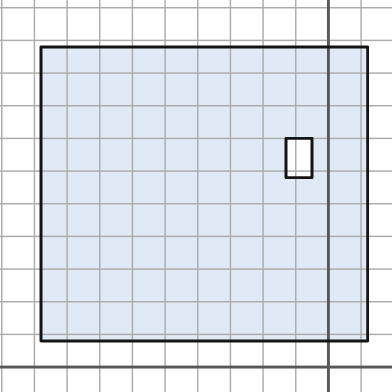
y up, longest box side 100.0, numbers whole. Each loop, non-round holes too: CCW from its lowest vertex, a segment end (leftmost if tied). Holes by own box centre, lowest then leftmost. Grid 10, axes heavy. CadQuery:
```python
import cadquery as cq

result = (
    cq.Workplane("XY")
    .moveTo(-88.0, 8.0)
    .lineTo(12.0, 8.0)
    .lineTo(12.0, 98.0)
    .lineTo(-88.0, 98.0)
    .close()
    .moveTo(-13.0, 58.0)
    .lineTo(-5.0, 58.0)
    .lineTo(-5.0, 70.0)
    .lineTo(-13.0, 70.0)
    .close()
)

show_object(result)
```